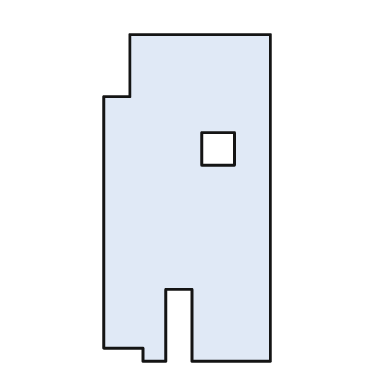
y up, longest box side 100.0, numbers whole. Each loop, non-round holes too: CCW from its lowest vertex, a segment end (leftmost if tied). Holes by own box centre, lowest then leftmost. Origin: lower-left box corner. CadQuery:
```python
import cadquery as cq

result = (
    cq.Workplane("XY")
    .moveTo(12.0, 0.0)
    .lineTo(19.0, 0.0)
    .lineTo(19.0, 22.0)
    .lineTo(27.0, 22.0)
    .lineTo(27.0, 0.0)
    .lineTo(51.0, 0.0)
    .lineTo(51.0, 100.0)
    .lineTo(8.0, 100.0)
    .lineTo(8.0, 81.0)
    .lineTo(0.0, 81.0)
    .lineTo(0.0, 4.0)
    .lineTo(12.0, 4.0)
    .close()
    .moveTo(30.0, 60.0)
    .lineTo(40.0, 60.0)
    .lineTo(40.0, 70.0)
    .lineTo(30.0, 70.0)
    .close()
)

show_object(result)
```